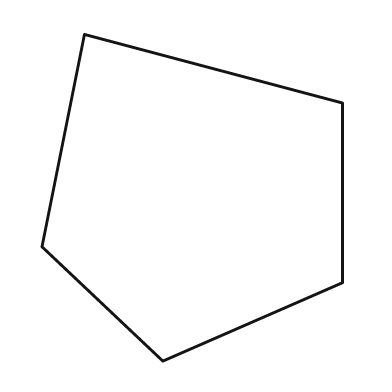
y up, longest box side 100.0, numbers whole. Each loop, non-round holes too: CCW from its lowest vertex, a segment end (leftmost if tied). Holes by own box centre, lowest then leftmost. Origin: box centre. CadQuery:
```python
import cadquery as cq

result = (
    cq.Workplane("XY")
    .moveTo(-9.0, -50.0)
    .lineTo(46.0, -26.0)
    .lineTo(46.0, 29.0)
    .lineTo(-33.0, 50.0)
    .lineTo(-46.0, -15.0)
    .close()
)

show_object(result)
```